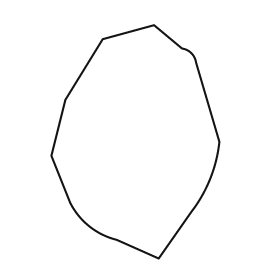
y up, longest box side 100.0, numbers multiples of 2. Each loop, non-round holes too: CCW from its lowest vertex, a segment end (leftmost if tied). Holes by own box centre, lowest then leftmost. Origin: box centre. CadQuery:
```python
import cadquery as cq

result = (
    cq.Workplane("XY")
    .moveTo(10.0, -50.0)
    .lineTo(24.0, -30.0)
    .threePointArc((32.0, -16.0), (36.0, 0.0))
    .lineTo(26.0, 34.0)
    .threePointArc((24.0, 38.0), (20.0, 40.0))
    .lineTo(8.0, 50.0)
    .lineTo(-14.0, 44.0)
    .lineTo(-30.0, 18.0)
    .lineTo(-36.0, -6.0)
    .lineTo(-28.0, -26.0)
    .threePointArc((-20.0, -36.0), (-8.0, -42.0))
    .close()
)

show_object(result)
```